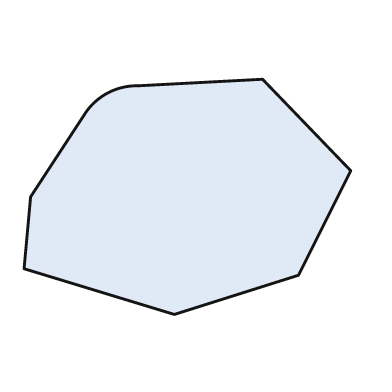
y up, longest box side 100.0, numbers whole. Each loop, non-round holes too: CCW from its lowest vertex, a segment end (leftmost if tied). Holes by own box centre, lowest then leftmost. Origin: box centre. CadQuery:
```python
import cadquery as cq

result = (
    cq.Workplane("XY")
    .moveTo(-4.0, -36.0)
    .lineTo(34.0, -24.0)
    .lineTo(50.0, 8.0)
    .lineTo(23.0, 36.0)
    .lineTo(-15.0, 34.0)
    .threePointArc((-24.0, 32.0), (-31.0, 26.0))
    .lineTo(-48.0, 0.0)
    .lineTo(-50.0, -22.0)
    .close()
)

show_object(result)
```